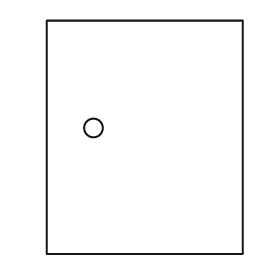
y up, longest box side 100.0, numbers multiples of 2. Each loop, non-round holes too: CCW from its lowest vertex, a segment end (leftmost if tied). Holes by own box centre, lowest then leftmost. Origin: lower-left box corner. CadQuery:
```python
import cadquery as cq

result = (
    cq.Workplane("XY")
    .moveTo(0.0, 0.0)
    .lineTo(84.0, 0.0)
    .lineTo(84.0, 100.0)
    .lineTo(0.0, 100.0)
    .close()
    .moveTo(20.0, 54.0)
    .circle(4.0)
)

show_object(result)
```